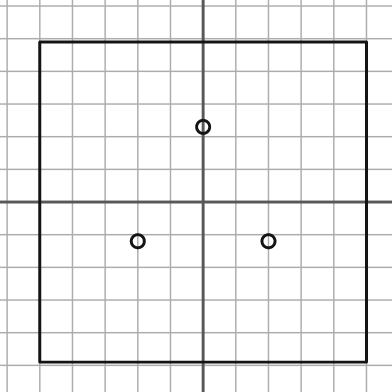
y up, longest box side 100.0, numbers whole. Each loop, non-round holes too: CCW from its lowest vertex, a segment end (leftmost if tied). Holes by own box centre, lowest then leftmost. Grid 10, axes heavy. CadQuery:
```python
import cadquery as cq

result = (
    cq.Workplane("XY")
    .moveTo(-50.0, -49.0)
    .lineTo(50.0, -49.0)
    .lineTo(50.0, 49.0)
    .lineTo(-50.0, 49.0)
    .close()
    .moveTo(-20.0, -12.0)
    .circle(2.0)
    .moveTo(20.0, -12.0)
    .circle(2.0)
    .moveTo(0.0, 23.0)
    .circle(2.0)
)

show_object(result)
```